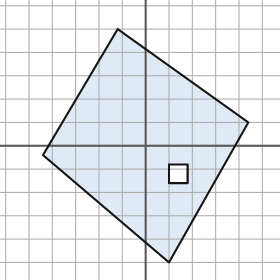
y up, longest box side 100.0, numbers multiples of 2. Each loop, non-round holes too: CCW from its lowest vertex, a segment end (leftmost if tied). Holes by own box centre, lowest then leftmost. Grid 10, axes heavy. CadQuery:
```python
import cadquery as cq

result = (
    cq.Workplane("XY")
    .moveTo(10.0, -50.0)
    .lineTo(44.0, 10.0)
    .lineTo(-12.0, 50.0)
    .lineTo(-44.0, -4.0)
    .close()
    .moveTo(10.0, -16.0)
    .lineTo(18.0, -16.0)
    .lineTo(18.0, -8.0)
    .lineTo(10.0, -8.0)
    .close()
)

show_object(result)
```